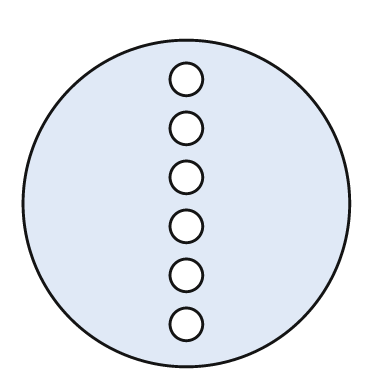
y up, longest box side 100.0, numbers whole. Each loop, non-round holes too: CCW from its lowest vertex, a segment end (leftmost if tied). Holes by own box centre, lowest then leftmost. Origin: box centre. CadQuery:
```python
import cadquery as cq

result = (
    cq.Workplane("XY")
    .moveTo(0.0, 0.0)
    .circle(50.0)
    .moveTo(0.0, -37.0)
    .circle(5.0)
    .moveTo(0.0, -22.0)
    .circle(5.0)
    .moveTo(0.0, -7.0)
    .circle(5.0)
    .moveTo(0.0, 8.0)
    .circle(5.0)
    .moveTo(0.0, 23.0)
    .circle(5.0)
    .moveTo(0.0, 38.0)
    .circle(5.0)
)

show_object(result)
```